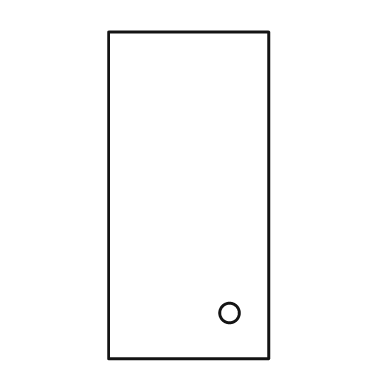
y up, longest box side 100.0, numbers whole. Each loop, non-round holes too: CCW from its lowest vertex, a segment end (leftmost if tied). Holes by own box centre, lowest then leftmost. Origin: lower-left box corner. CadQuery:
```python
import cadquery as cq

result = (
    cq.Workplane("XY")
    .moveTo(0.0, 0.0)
    .lineTo(49.0, 0.0)
    .lineTo(49.0, 100.0)
    .lineTo(0.0, 100.0)
    .close()
    .moveTo(37.0, 14.0)
    .circle(3.0)
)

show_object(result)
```